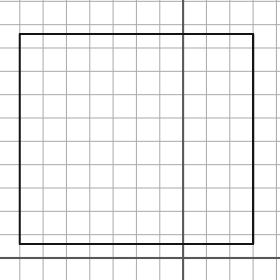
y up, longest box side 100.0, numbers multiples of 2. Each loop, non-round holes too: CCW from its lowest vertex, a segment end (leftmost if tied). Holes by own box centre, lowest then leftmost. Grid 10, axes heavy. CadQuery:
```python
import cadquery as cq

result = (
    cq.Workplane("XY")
    .moveTo(-70.0, 6.0)
    .lineTo(30.0, 6.0)
    .lineTo(30.0, 96.0)
    .lineTo(-70.0, 96.0)
    .close()
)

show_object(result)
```